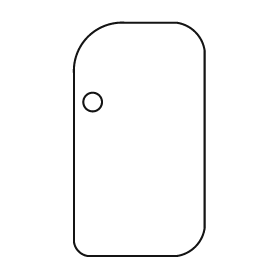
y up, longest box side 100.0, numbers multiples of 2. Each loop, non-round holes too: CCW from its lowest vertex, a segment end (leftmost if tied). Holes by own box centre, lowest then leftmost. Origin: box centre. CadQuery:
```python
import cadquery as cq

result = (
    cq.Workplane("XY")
    .moveTo(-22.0, -50.0)
    .lineTo(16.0, -50.0)
    .threePointArc((24.0, -46.0), (28.0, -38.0))
    .lineTo(28.0, 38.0)
    .threePointArc((24.0, 46.0), (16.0, 50.0))
    .lineTo(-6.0, 50.0)
    .threePointArc((-22.0, 44.0), (-28.0, 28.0))
    .lineTo(-28.0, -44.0)
    .threePointArc((-26.0, -48.0), (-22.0, -50.0))
    .close()
    .moveTo(-20.0, 16.0)
    .circle(4.0)
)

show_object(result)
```